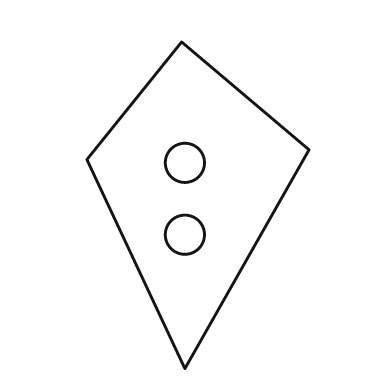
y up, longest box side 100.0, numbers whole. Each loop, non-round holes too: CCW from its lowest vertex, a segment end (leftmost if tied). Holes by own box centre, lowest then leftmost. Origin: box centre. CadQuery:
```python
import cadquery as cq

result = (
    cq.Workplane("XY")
    .moveTo(-4.0, -50.0)
    .lineTo(34.0, 17.0)
    .lineTo(-5.0, 50.0)
    .lineTo(-34.0, 14.0)
    .close()
    .moveTo(-4.0, -9.0)
    .circle(6.0)
    .moveTo(-4.0, 13.0)
    .circle(6.0)
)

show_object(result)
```